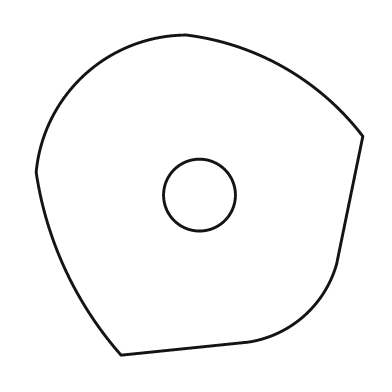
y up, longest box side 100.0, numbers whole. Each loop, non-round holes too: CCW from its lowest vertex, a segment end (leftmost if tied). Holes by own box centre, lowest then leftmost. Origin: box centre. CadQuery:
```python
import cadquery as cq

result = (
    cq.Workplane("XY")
    .moveTo(-24.0, -49.0)
    .lineTo(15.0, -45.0)
    .threePointArc((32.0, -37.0), (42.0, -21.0))
    .lineTo(50.0, 18.0)
    .threePointArc((26.0, 39.0), (-4.0, 49.0))
    .threePointArc((-35.0, 37.0), (-50.0, 7.0))
    .threePointArc((-41.0, -23.0), (-24.0, -49.0))
    .close()
    .moveTo(0.0, 0.0)
    .circle(11.0)
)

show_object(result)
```